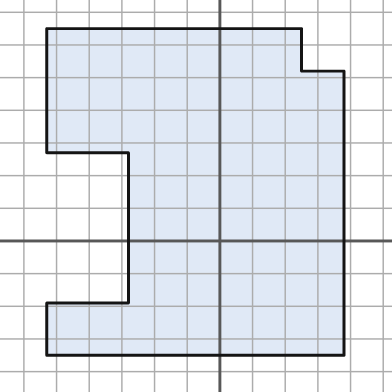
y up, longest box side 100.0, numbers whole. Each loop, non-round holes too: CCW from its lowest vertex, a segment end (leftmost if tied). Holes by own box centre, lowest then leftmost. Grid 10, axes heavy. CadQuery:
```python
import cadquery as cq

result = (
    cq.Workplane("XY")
    .moveTo(-53.0, -35.0)
    .lineTo(38.0, -35.0)
    .lineTo(38.0, 52.0)
    .lineTo(25.0, 52.0)
    .lineTo(25.0, 65.0)
    .lineTo(-53.0, 65.0)
    .lineTo(-53.0, 27.0)
    .lineTo(-28.0, 27.0)
    .lineTo(-28.0, -19.0)
    .lineTo(-53.0, -19.0)
    .close()
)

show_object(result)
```